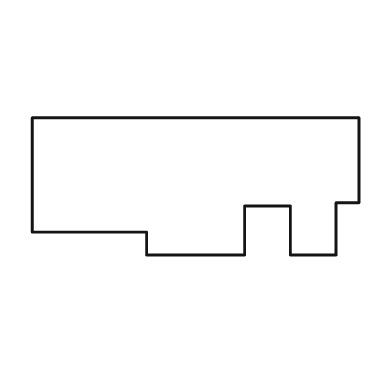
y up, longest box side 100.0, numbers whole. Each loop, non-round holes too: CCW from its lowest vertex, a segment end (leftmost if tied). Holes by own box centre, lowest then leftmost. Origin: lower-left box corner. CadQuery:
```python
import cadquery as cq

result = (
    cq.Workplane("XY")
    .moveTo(35.0, 0.0)
    .lineTo(65.0, 0.0)
    .lineTo(65.0, 15.0)
    .lineTo(79.0, 15.0)
    .lineTo(79.0, 0.0)
    .lineTo(93.0, 0.0)
    .lineTo(93.0, 16.0)
    .lineTo(100.0, 16.0)
    .lineTo(100.0, 42.0)
    .lineTo(0.0, 42.0)
    .lineTo(0.0, 7.0)
    .lineTo(35.0, 7.0)
    .close()
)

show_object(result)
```